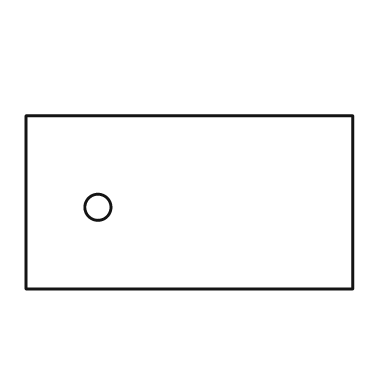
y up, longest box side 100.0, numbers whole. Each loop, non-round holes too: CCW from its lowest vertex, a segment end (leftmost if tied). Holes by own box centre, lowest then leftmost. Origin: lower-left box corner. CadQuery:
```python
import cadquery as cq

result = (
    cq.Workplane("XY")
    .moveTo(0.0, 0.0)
    .lineTo(100.0, 0.0)
    .lineTo(100.0, 53.0)
    .lineTo(0.0, 53.0)
    .close()
    .moveTo(22.0, 25.0)
    .circle(4.0)
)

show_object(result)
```